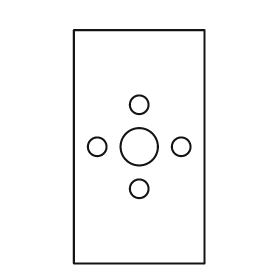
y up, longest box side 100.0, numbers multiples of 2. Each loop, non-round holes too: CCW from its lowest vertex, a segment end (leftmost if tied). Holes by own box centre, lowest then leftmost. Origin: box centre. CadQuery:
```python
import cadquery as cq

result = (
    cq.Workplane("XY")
    .moveTo(-28.0, -50.0)
    .lineTo(28.0, -50.0)
    .lineTo(28.0, 50.0)
    .lineTo(-28.0, 50.0)
    .close()
    .moveTo(0.0, -18.0)
    .circle(4.0)
    .moveTo(-18.0, 0.0)
    .circle(4.0)
    .moveTo(0.0, 0.0)
    .circle(8.0)
    .moveTo(18.0, 0.0)
    .circle(4.0)
    .moveTo(0.0, 18.0)
    .circle(4.0)
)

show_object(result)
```